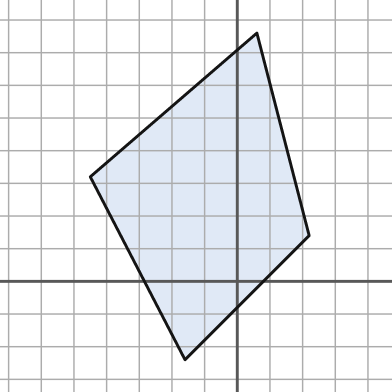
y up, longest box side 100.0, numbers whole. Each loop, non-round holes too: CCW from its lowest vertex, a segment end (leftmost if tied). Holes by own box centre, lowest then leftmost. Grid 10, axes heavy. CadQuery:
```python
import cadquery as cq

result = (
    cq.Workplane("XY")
    .moveTo(-16.0, -24.0)
    .lineTo(22.0, 14.0)
    .lineTo(6.0, 76.0)
    .lineTo(-45.0, 32.0)
    .close()
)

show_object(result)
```